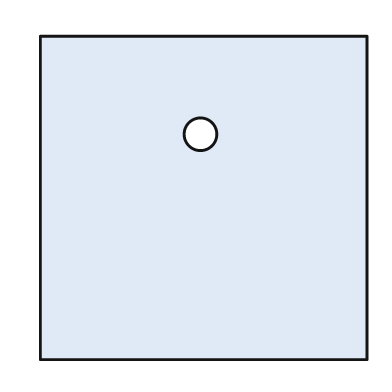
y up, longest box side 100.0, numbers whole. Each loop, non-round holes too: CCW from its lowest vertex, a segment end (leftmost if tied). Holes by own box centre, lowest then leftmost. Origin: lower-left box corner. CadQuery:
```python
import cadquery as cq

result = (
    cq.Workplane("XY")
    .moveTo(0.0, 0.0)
    .lineTo(100.0, 0.0)
    .lineTo(100.0, 99.0)
    .lineTo(0.0, 99.0)
    .close()
    .moveTo(49.0, 69.0)
    .circle(5.0)
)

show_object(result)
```